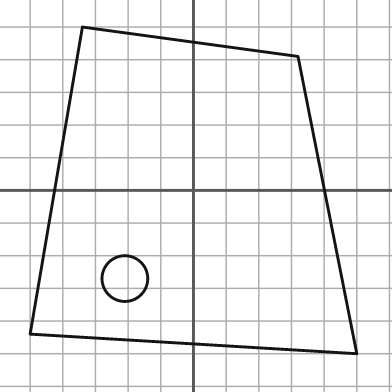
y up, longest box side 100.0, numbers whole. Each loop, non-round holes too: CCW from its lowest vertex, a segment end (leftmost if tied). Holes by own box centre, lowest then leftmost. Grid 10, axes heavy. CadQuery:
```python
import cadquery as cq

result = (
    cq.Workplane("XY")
    .moveTo(50.0, -50.0)
    .lineTo(32.0, 41.0)
    .lineTo(-34.0, 50.0)
    .lineTo(-50.0, -44.0)
    .close()
    .moveTo(-21.0, -27.0)
    .circle(7.0)
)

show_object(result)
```